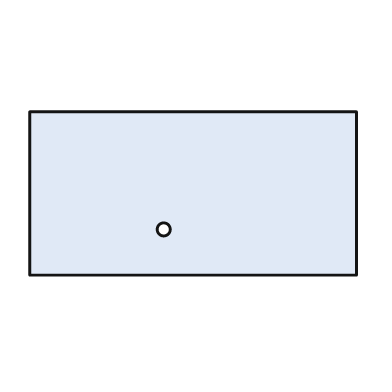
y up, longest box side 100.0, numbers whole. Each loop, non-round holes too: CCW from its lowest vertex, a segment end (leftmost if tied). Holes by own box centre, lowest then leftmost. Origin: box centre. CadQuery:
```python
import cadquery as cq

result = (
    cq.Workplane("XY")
    .moveTo(-50.0, -25.0)
    .lineTo(50.0, -25.0)
    .lineTo(50.0, 25.0)
    .lineTo(-50.0, 25.0)
    .close()
    .moveTo(-9.0, -11.0)
    .circle(2.0)
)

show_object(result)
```